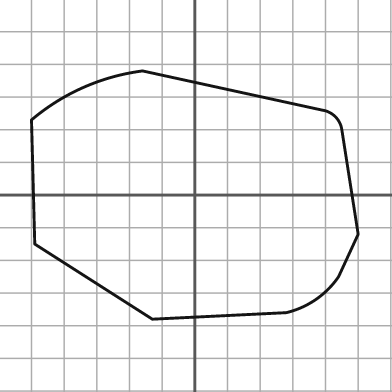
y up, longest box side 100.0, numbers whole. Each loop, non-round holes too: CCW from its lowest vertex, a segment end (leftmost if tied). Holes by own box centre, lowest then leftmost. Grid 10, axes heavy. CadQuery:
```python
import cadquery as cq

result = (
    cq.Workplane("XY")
    .moveTo(-13.0, -38.0)
    .lineTo(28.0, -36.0)
    .threePointArc((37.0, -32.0), (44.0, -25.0))
    .lineTo(50.0, -12.0)
    .lineTo(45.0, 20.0)
    .threePointArc((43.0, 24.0), (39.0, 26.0))
    .lineTo(-16.0, 38.0)
    .threePointArc((-34.0, 33.0), (-50.0, 23.0))
    .lineTo(-49.0, -15.0)
    .close()
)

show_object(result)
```